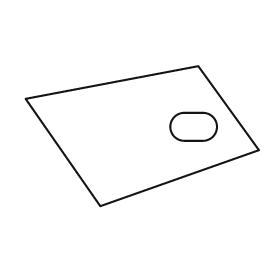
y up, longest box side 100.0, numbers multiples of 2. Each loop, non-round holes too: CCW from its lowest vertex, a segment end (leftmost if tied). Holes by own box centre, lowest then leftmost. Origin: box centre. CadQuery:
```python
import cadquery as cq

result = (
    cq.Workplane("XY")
    .moveTo(-18.0, -30.0)
    .lineTo(50.0, -6.0)
    .lineTo(24.0, 30.0)
    .lineTo(-50.0, 16.0)
    .close()
    .moveTo(18.0, -2.0)
    .lineTo(26.0, -2.0)
    .threePointArc((32.0, 4.0), (26.0, 10.0))
    .lineTo(18.0, 10.0)
    .threePointArc((12.0, 4.0), (18.0, -2.0))
    .close()
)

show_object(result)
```